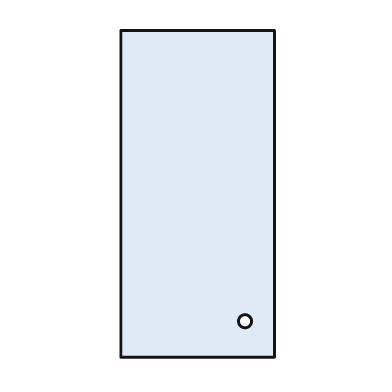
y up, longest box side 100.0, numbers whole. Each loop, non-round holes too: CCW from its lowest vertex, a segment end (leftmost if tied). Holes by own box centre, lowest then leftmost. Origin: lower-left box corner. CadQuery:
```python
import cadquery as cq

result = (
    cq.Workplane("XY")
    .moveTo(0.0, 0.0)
    .lineTo(47.0, 0.0)
    .lineTo(47.0, 100.0)
    .lineTo(0.0, 100.0)
    .close()
    .moveTo(38.0, 11.0)
    .circle(2.0)
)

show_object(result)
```